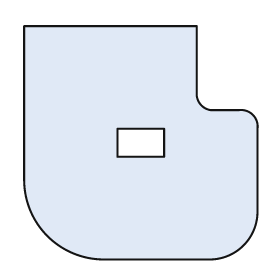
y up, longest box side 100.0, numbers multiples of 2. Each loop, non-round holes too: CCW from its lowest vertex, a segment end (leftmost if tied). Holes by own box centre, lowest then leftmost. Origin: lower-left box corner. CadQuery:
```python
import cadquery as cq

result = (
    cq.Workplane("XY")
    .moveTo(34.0, 0.0)
    .lineTo(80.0, 0.0)
    .threePointArc((94.0, 6.0), (100.0, 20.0))
    .lineTo(100.0, 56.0)
    .threePointArc((98.0, 62.0), (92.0, 64.0))
    .lineTo(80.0, 64.0)
    .threePointArc((76.0, 66.0), (74.0, 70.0))
    .lineTo(74.0, 100.0)
    .lineTo(0.0, 100.0)
    .lineTo(0.0, 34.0)
    .threePointArc((10.0, 10.0), (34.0, 0.0))
    .close()
    .moveTo(40.0, 44.0)
    .lineTo(60.0, 44.0)
    .lineTo(60.0, 56.0)
    .lineTo(40.0, 56.0)
    .close()
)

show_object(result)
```